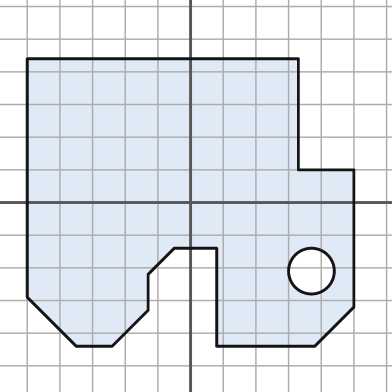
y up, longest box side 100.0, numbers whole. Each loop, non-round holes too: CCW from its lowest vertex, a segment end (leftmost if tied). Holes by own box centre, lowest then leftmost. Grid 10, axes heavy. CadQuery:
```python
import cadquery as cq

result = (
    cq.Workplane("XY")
    .moveTo(-35.0, -44.0)
    .lineTo(-24.0, -44.0)
    .lineTo(-13.0, -33.0)
    .lineTo(-13.0, -22.0)
    .lineTo(-5.0, -14.0)
    .lineTo(8.0, -14.0)
    .lineTo(8.0, -44.0)
    .lineTo(38.0, -44.0)
    .lineTo(50.0, -32.0)
    .lineTo(50.0, 10.0)
    .lineTo(33.0, 10.0)
    .lineTo(33.0, 44.0)
    .lineTo(-50.0, 44.0)
    .lineTo(-50.0, -29.0)
    .close()
    .moveTo(37.0, -21.0)
    .circle(7.0)
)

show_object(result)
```